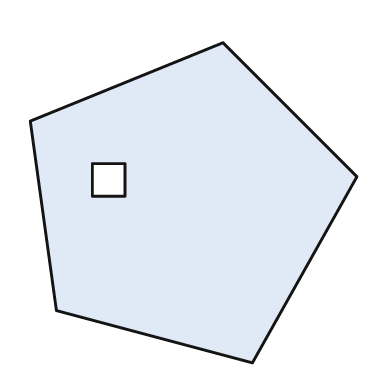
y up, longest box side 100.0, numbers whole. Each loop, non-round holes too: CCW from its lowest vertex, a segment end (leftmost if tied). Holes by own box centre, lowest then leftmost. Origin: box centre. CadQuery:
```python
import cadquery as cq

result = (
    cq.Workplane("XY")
    .moveTo(18.0, -49.0)
    .lineTo(50.0, 8.0)
    .lineTo(9.0, 49.0)
    .lineTo(-50.0, 25.0)
    .lineTo(-42.0, -33.0)
    .close()
    .moveTo(-31.0, 2.0)
    .lineTo(-21.0, 2.0)
    .lineTo(-21.0, 12.0)
    .lineTo(-31.0, 12.0)
    .close()
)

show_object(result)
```